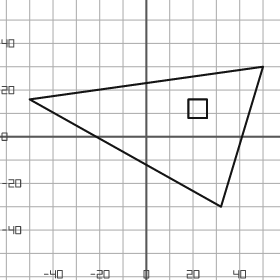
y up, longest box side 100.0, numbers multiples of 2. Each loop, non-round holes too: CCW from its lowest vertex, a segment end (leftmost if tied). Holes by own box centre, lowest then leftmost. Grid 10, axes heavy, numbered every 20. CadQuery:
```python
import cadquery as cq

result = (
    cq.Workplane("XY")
    .moveTo(32.0, -30.0)
    .lineTo(50.0, 30.0)
    .lineTo(-50.0, 16.0)
    .close()
    .moveTo(18.0, 8.0)
    .lineTo(26.0, 8.0)
    .lineTo(26.0, 16.0)
    .lineTo(18.0, 16.0)
    .close()
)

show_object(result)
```